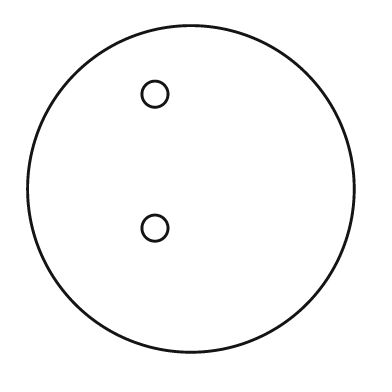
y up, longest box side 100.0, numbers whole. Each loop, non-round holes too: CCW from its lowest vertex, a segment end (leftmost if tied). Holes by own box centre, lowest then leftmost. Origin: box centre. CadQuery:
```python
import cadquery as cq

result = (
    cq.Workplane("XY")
    .moveTo(0.0, 0.0)
    .circle(50.0)
    .moveTo(-11.0, -12.0)
    .circle(4.0)
    .moveTo(-11.0, 29.0)
    .circle(4.0)
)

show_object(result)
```